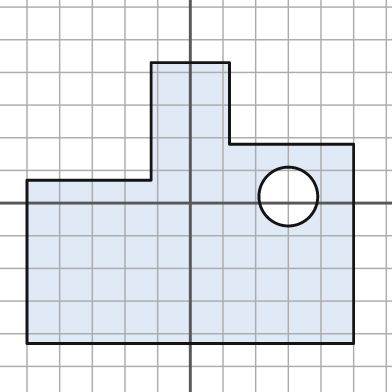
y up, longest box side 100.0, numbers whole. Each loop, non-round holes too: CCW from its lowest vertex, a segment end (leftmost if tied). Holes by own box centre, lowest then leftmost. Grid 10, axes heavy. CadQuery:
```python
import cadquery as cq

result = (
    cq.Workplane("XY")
    .moveTo(-50.0, -43.0)
    .lineTo(50.0, -43.0)
    .lineTo(50.0, 18.0)
    .lineTo(12.0, 18.0)
    .lineTo(12.0, 43.0)
    .lineTo(-12.0, 43.0)
    .lineTo(-12.0, 7.0)
    .lineTo(-50.0, 7.0)
    .close()
    .moveTo(30.0, 2.0)
    .circle(9.0)
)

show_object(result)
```